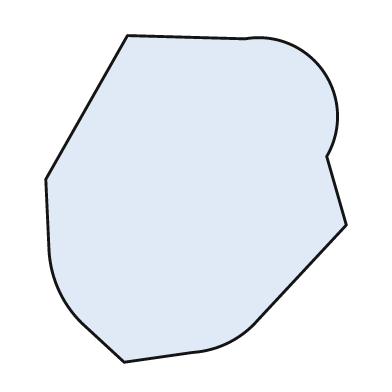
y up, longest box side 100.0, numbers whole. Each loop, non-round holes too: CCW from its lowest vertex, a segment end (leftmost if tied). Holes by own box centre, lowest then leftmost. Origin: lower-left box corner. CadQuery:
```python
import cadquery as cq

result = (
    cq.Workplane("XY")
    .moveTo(24.0, 0.0)
    .lineTo(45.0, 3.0)
    .threePointArc((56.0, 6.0), (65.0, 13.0))
    .lineTo(92.0, 42.0)
    .lineTo(86.0, 63.0)
    .threePointArc((85.0, 89.0), (61.0, 99.0))
    .lineTo(25.0, 100.0)
    .lineTo(0.0, 56.0)
    .lineTo(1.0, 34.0)
    .threePointArc((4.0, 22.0), (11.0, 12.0))
    .close()
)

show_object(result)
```